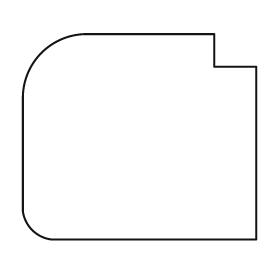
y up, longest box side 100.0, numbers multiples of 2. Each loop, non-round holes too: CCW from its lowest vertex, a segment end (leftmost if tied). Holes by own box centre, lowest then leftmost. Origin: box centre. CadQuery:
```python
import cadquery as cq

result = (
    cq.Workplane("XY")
    .moveTo(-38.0, -44.0)
    .lineTo(50.0, -44.0)
    .lineTo(50.0, 30.0)
    .lineTo(32.0, 30.0)
    .lineTo(32.0, 44.0)
    .lineTo(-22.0, 44.0)
    .threePointArc((-42.0, 36.0), (-50.0, 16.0))
    .lineTo(-50.0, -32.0)
    .threePointArc((-46.0, -40.0), (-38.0, -44.0))
    .close()
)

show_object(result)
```